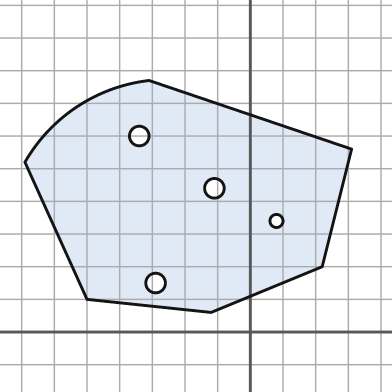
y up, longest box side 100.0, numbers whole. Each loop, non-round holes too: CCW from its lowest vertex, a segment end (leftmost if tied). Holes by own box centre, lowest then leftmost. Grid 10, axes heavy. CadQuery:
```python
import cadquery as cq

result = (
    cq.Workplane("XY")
    .moveTo(-12.0, 6.0)
    .lineTo(22.0, 20.0)
    .lineTo(31.0, 56.0)
    .lineTo(-31.0, 77.0)
    .threePointArc((-53.0, 69.0), (-69.0, 52.0))
    .lineTo(-50.0, 10.0)
    .close()
    .moveTo(-29.0, 15.0)
    .circle(3.0)
    .moveTo(8.0, 34.0)
    .circle(2.0)
    .moveTo(-11.0, 44.0)
    .circle(3.0)
    .moveTo(-34.0, 60.0)
    .circle(3.0)
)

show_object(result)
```